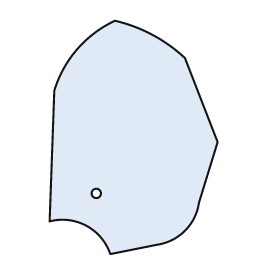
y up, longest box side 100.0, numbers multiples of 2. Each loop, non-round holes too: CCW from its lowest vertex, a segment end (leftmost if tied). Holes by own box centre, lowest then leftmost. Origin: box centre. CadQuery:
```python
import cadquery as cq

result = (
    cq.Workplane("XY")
    .moveTo(-10.0, -50.0)
    .lineTo(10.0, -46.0)
    .threePointArc((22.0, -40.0), (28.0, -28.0))
    .lineTo(36.0, -2.0)
    .lineTo(22.0, 34.0)
    .threePointArc((8.0, 44.0), (-8.0, 50.0))
    .threePointArc((-24.0, 38.0), (-34.0, 20.0))
    .lineTo(-36.0, -36.0)
    .threePointArc((-20.0, -38.0), (-10.0, -50.0))
    .close()
    .moveTo(-16.0, -24.0)
    .circle(2.0)
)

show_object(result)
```